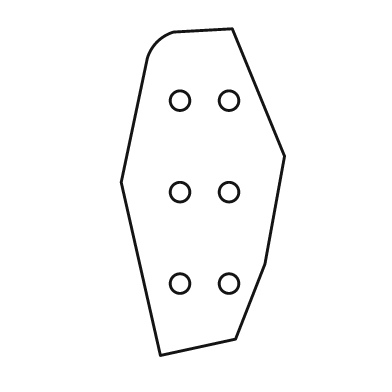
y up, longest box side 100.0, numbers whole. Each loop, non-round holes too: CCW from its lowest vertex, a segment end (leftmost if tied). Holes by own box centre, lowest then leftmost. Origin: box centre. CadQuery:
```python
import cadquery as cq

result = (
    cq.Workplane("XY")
    .moveTo(-13.0, -50.0)
    .lineTo(10.0, -45.0)
    .lineTo(19.0, -22.0)
    .lineTo(25.0, 11.0)
    .lineTo(9.0, 50.0)
    .lineTo(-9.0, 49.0)
    .threePointArc((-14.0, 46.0), (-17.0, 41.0))
    .lineTo(-25.0, 3.0)
    .close()
    .moveTo(-7.0, -28.0)
    .circle(3.0)
    .moveTo(8.0, -28.0)
    .circle(3.0)
    .moveTo(-7.0, 0.0)
    .circle(3.0)
    .moveTo(8.0, 0.0)
    .circle(3.0)
    .moveTo(-7.0, 28.0)
    .circle(3.0)
    .moveTo(8.0, 28.0)
    .circle(3.0)
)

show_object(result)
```